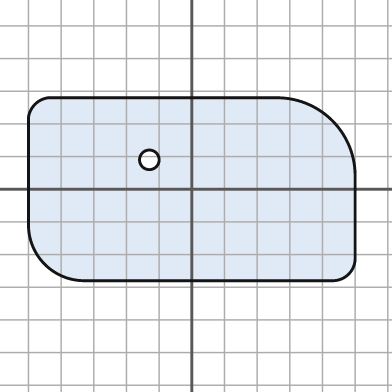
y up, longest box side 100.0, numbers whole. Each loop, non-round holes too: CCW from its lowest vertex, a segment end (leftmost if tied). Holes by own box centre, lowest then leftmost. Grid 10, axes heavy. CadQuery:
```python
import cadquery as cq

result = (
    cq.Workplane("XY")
    .moveTo(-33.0, -28.0)
    .lineTo(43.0, -28.0)
    .threePointArc((48.0, -26.0), (50.0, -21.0))
    .lineTo(50.0, 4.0)
    .threePointArc((43.0, 21.0), (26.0, 28.0))
    .lineTo(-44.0, 28.0)
    .threePointArc((-48.0, 26.0), (-50.0, 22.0))
    .lineTo(-50.0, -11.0)
    .threePointArc((-45.0, -23.0), (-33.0, -28.0))
    .close()
    .moveTo(-13.0, 9.0)
    .circle(3.0)
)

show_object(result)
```